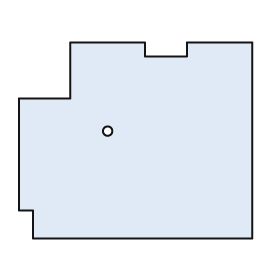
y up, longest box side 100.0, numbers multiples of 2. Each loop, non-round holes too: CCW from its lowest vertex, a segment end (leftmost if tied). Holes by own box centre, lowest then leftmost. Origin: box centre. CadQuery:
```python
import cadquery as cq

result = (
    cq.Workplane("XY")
    .moveTo(-44.0, -42.0)
    .lineTo(50.0, -42.0)
    .lineTo(50.0, 42.0)
    .lineTo(22.0, 42.0)
    .lineTo(22.0, 36.0)
    .lineTo(4.0, 36.0)
    .lineTo(4.0, 42.0)
    .lineTo(-28.0, 42.0)
    .lineTo(-28.0, 18.0)
    .lineTo(-50.0, 18.0)
    .lineTo(-50.0, -30.0)
    .lineTo(-44.0, -30.0)
    .close()
    .moveTo(-12.0, 4.0)
    .circle(2.0)
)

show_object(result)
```